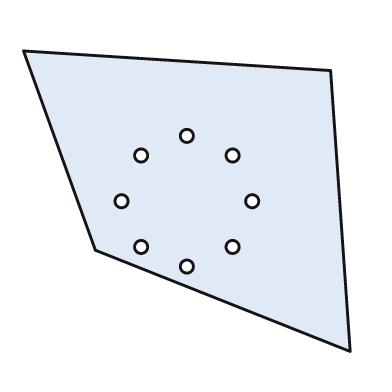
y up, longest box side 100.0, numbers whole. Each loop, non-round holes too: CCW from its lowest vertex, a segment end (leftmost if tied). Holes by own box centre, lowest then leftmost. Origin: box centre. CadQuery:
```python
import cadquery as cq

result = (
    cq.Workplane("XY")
    .moveTo(50.0, -46.0)
    .lineTo(44.0, 40.0)
    .lineTo(-50.0, 46.0)
    .lineTo(-28.0, -15.0)
    .close()
    .moveTo(0.0, -20.0)
    .circle(2.0)
    .moveTo(-14.0, -14.0)
    .circle(2.0)
    .moveTo(14.0, -14.0)
    .circle(2.0)
    .moveTo(-20.0, 0.0)
    .circle(2.0)
    .moveTo(20.0, 0.0)
    .circle(2.0)
    .moveTo(-14.0, 14.0)
    .circle(2.0)
    .moveTo(14.0, 14.0)
    .circle(2.0)
    .moveTo(0.0, 20.0)
    .circle(2.0)
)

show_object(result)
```